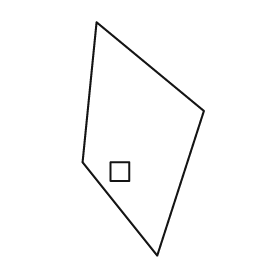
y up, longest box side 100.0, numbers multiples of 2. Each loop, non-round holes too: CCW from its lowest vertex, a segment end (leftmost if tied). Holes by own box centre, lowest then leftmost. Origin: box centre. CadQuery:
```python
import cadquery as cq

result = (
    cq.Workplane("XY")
    .moveTo(6.0, -50.0)
    .lineTo(26.0, 12.0)
    .lineTo(-20.0, 50.0)
    .lineTo(-26.0, -10.0)
    .close()
    .moveTo(-14.0, -18.0)
    .lineTo(-6.0, -18.0)
    .lineTo(-6.0, -10.0)
    .lineTo(-14.0, -10.0)
    .close()
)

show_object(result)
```